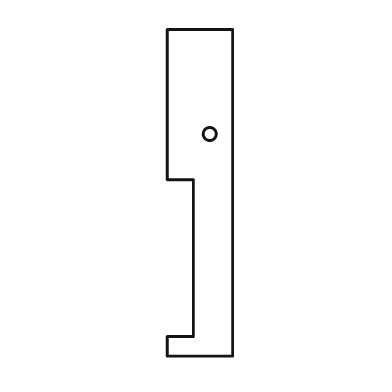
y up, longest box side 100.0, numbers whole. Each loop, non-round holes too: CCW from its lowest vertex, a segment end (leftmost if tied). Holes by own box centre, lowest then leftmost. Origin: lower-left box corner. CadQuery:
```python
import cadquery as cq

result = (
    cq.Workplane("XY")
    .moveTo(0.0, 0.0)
    .lineTo(20.0, 0.0)
    .lineTo(20.0, 100.0)
    .lineTo(0.0, 100.0)
    .lineTo(0.0, 54.0)
    .lineTo(8.0, 54.0)
    .lineTo(8.0, 6.0)
    .lineTo(0.0, 6.0)
    .close()
    .moveTo(13.0, 68.0)
    .circle(2.0)
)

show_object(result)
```